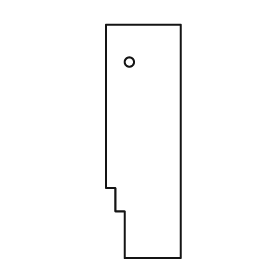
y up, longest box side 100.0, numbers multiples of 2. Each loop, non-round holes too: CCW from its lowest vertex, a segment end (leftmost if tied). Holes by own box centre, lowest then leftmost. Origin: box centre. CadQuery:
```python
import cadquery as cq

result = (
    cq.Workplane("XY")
    .moveTo(-8.0, -50.0)
    .lineTo(16.0, -50.0)
    .lineTo(16.0, 50.0)
    .lineTo(-16.0, 50.0)
    .lineTo(-16.0, -20.0)
    .lineTo(-12.0, -20.0)
    .lineTo(-12.0, -30.0)
    .lineTo(-8.0, -30.0)
    .close()
    .moveTo(-6.0, 34.0)
    .circle(2.0)
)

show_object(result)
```